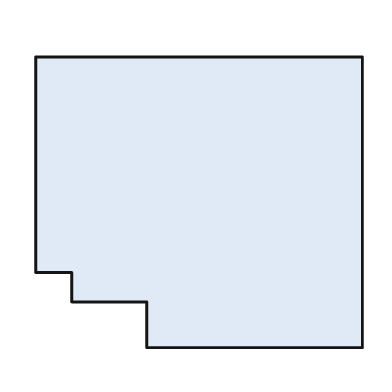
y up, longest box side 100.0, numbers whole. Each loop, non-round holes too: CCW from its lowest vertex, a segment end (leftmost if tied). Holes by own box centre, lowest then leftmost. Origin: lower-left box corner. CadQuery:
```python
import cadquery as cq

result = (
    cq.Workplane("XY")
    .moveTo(34.0, 0.0)
    .lineTo(100.0, 0.0)
    .lineTo(100.0, 89.0)
    .lineTo(0.0, 89.0)
    .lineTo(0.0, 23.0)
    .lineTo(11.0, 23.0)
    .lineTo(11.0, 14.0)
    .lineTo(34.0, 14.0)
    .close()
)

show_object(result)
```